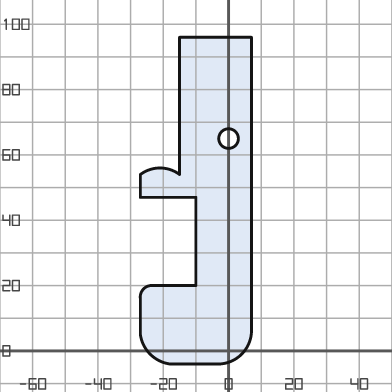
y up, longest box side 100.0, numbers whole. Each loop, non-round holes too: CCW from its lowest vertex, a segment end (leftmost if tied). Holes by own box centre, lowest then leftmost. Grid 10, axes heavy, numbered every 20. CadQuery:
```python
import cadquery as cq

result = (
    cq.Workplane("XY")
    .moveTo(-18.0, -4.0)
    .lineTo(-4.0, -4.0)
    .threePointArc((4.0, -1.0), (7.0, 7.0))
    .lineTo(7.0, 96.0)
    .lineTo(-15.0, 96.0)
    .lineTo(-15.0, 54.0)
    .threePointArc((-21.0, 56.0), (-27.0, 54.0))
    .lineTo(-27.0, 47.0)
    .lineTo(-10.0, 47.0)
    .lineTo(-10.0, 20.0)
    .lineTo(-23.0, 20.0)
    .threePointArc((-26.0, 19.0), (-27.0, 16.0))
    .lineTo(-27.0, 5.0)
    .threePointArc((-24.0, -1.0), (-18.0, -4.0))
    .close()
    .moveTo(0.0, 65.0)
    .circle(3.0)
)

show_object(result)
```